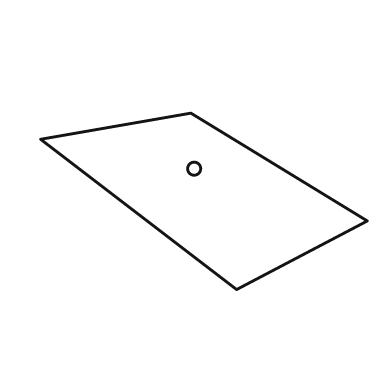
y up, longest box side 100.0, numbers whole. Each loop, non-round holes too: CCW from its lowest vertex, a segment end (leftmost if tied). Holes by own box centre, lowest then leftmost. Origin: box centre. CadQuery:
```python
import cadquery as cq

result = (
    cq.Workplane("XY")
    .moveTo(10.0, -27.0)
    .lineTo(50.0, -6.0)
    .lineTo(-4.0, 27.0)
    .lineTo(-50.0, 19.0)
    .close()
    .moveTo(-3.0, 10.0)
    .circle(2.0)
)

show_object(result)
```